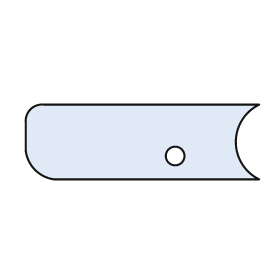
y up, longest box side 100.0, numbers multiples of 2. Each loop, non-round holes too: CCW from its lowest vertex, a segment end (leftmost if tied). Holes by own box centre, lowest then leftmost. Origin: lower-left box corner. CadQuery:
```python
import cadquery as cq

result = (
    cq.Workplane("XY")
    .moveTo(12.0, 0.0)
    .lineTo(100.0, 0.0)
    .threePointArc((90.0, 16.0), (100.0, 32.0))
    .lineTo(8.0, 32.0)
    .threePointArc((2.0, 30.0), (0.0, 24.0))
    .lineTo(0.0, 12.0)
    .threePointArc((4.0, 4.0), (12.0, 0.0))
    .close()
    .moveTo(64.0, 10.0)
    .circle(4.0)
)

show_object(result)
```